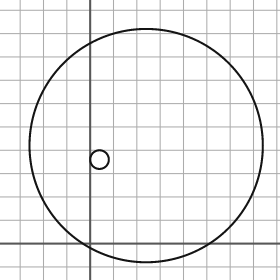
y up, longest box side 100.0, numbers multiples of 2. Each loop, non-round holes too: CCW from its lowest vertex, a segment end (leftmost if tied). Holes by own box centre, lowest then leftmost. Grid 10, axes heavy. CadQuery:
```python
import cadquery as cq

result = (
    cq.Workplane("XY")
    .moveTo(24.0, 42.0)
    .circle(50.0)
    .moveTo(4.0, 36.0)
    .circle(4.0)
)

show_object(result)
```